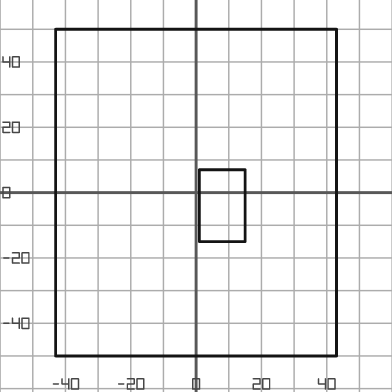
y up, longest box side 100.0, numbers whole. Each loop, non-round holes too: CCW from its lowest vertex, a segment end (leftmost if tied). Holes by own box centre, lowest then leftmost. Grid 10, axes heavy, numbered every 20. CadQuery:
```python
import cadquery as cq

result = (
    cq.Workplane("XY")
    .moveTo(-43.0, -50.0)
    .lineTo(43.0, -50.0)
    .lineTo(43.0, 50.0)
    .lineTo(-43.0, 50.0)
    .close()
    .moveTo(1.0, -15.0)
    .lineTo(15.0, -15.0)
    .lineTo(15.0, 7.0)
    .lineTo(1.0, 7.0)
    .close()
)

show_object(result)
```